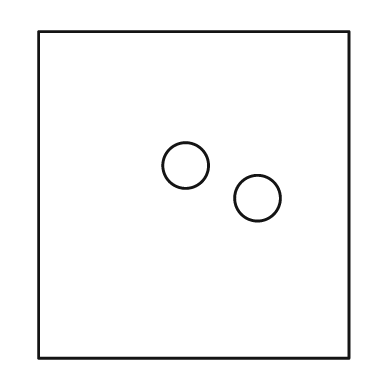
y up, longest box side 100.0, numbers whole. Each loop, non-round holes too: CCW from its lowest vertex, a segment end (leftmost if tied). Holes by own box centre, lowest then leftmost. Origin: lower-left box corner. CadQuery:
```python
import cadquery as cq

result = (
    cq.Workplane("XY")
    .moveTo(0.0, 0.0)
    .lineTo(95.0, 0.0)
    .lineTo(95.0, 100.0)
    .lineTo(0.0, 100.0)
    .close()
    .moveTo(67.0, 49.0)
    .circle(7.0)
    .moveTo(45.0, 59.0)
    .circle(7.0)
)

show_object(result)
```